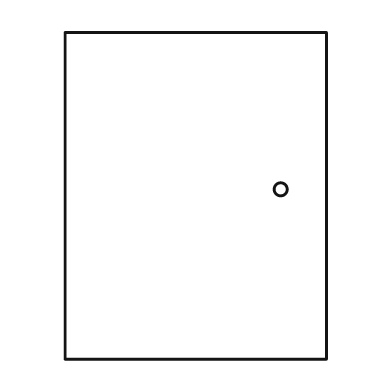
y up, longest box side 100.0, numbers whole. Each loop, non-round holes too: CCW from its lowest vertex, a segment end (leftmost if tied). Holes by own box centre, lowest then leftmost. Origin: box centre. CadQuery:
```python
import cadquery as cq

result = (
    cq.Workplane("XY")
    .moveTo(-40.0, -50.0)
    .lineTo(40.0, -50.0)
    .lineTo(40.0, 50.0)
    .lineTo(-40.0, 50.0)
    .close()
    .moveTo(26.0, 2.0)
    .circle(2.0)
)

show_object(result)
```